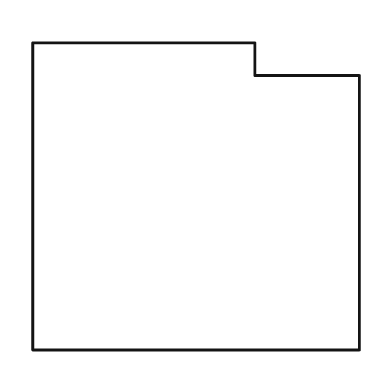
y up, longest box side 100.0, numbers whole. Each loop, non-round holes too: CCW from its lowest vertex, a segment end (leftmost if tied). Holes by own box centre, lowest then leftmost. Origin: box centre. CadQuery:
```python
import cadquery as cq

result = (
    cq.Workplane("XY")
    .moveTo(-50.0, -47.0)
    .lineTo(50.0, -47.0)
    .lineTo(50.0, 37.0)
    .lineTo(18.0, 37.0)
    .lineTo(18.0, 47.0)
    .lineTo(-50.0, 47.0)
    .close()
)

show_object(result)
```